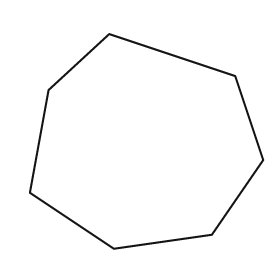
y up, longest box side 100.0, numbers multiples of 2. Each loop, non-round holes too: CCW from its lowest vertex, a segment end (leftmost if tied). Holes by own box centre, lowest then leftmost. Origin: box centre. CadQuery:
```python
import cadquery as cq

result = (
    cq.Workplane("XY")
    .moveTo(-14.0, -46.0)
    .lineTo(28.0, -40.0)
    .lineTo(50.0, -8.0)
    .lineTo(38.0, 28.0)
    .lineTo(-16.0, 46.0)
    .lineTo(-42.0, 22.0)
    .lineTo(-50.0, -22.0)
    .close()
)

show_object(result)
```